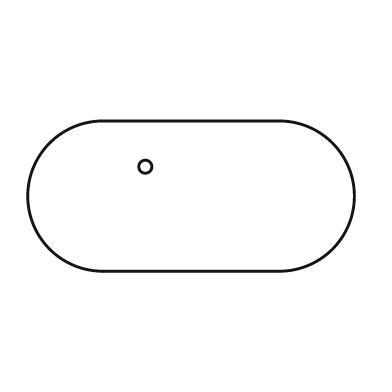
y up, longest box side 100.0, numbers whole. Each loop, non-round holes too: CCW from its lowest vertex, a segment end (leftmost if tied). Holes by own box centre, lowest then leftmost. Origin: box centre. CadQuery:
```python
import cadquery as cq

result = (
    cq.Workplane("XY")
    .moveTo(-27.0, -23.0)
    .lineTo(27.0, -23.0)
    .threePointArc((50.0, 0.0), (27.0, 23.0))
    .lineTo(-27.0, 23.0)
    .threePointArc((-50.0, 0.0), (-27.0, -23.0))
    .close()
    .moveTo(-14.0, 9.0)
    .circle(2.0)
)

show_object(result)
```